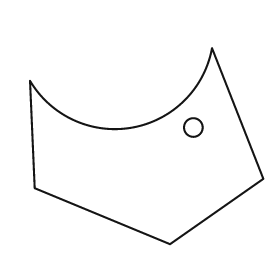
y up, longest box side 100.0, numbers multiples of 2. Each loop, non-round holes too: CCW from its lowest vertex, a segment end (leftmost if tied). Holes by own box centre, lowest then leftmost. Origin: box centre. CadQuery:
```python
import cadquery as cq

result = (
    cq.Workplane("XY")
    .moveTo(10.0, -42.0)
    .lineTo(50.0, -14.0)
    .lineTo(28.0, 42.0)
    .threePointArc((-6.0, 8.0), (-50.0, 28.0))
    .lineTo(-48.0, -18.0)
    .close()
    .moveTo(20.0, 8.0)
    .circle(4.0)
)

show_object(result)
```